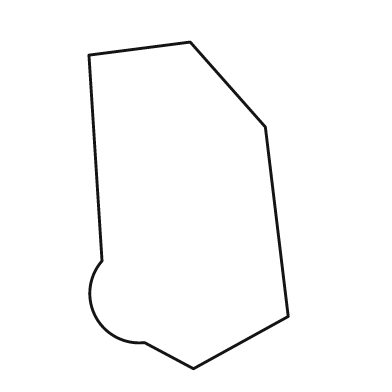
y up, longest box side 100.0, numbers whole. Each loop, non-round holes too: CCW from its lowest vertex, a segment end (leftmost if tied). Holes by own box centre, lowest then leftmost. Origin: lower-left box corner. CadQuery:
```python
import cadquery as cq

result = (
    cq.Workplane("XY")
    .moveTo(32.0, 0.0)
    .lineTo(61.0, 16.0)
    .lineTo(54.0, 74.0)
    .lineTo(31.0, 100.0)
    .lineTo(0.0, 96.0)
    .lineTo(4.0, 33.0)
    .threePointArc((2.0, 16.0), (17.0, 8.0))
    .close()
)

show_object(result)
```